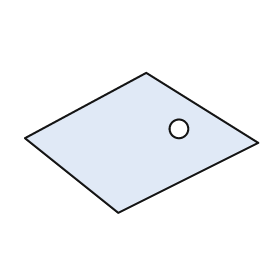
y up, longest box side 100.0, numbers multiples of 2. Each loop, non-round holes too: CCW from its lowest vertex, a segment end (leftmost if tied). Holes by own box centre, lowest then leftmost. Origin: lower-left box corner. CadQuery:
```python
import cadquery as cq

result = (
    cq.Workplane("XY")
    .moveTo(40.0, 0.0)
    .lineTo(100.0, 30.0)
    .lineTo(52.0, 60.0)
    .lineTo(0.0, 32.0)
    .close()
    .moveTo(66.0, 36.0)
    .circle(4.0)
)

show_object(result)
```